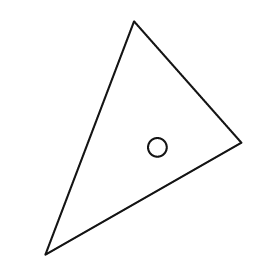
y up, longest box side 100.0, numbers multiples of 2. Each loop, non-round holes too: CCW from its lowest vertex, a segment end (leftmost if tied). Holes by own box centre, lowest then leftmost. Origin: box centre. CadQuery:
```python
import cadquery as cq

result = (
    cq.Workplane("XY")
    .moveTo(-42.0, -50.0)
    .lineTo(42.0, -2.0)
    .lineTo(-4.0, 50.0)
    .close()
    .moveTo(6.0, -4.0)
    .circle(4.0)
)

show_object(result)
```